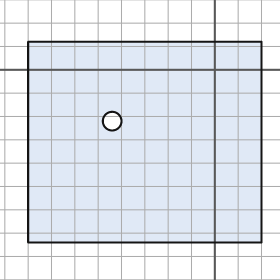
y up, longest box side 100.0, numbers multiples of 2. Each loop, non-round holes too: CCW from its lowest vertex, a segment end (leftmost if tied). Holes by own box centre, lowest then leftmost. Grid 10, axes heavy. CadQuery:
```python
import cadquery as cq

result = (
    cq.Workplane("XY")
    .moveTo(-80.0, -74.0)
    .lineTo(20.0, -74.0)
    .lineTo(20.0, 12.0)
    .lineTo(-80.0, 12.0)
    .close()
    .moveTo(-44.0, -22.0)
    .circle(4.0)
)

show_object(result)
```